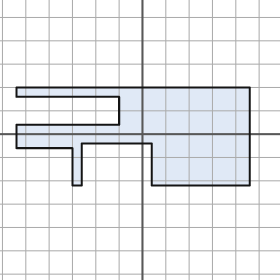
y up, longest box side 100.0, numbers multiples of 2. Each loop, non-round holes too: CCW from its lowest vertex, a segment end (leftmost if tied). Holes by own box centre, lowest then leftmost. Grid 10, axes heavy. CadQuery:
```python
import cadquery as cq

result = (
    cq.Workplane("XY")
    .moveTo(-30.0, -22.0)
    .lineTo(-26.0, -22.0)
    .lineTo(-26.0, -4.0)
    .lineTo(4.0, -4.0)
    .lineTo(4.0, -22.0)
    .lineTo(46.0, -22.0)
    .lineTo(46.0, 20.0)
    .lineTo(-54.0, 20.0)
    .lineTo(-54.0, 16.0)
    .lineTo(-10.0, 16.0)
    .lineTo(-10.0, 4.0)
    .lineTo(-54.0, 4.0)
    .lineTo(-54.0, -6.0)
    .lineTo(-30.0, -6.0)
    .close()
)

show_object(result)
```